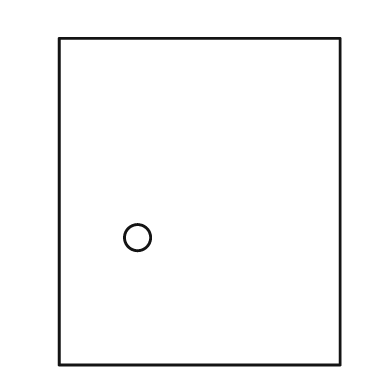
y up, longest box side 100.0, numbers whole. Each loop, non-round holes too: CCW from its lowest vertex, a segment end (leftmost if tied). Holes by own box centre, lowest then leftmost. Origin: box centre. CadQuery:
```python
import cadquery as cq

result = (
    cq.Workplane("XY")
    .moveTo(-43.0, -50.0)
    .lineTo(43.0, -50.0)
    .lineTo(43.0, 50.0)
    .lineTo(-43.0, 50.0)
    .close()
    .moveTo(-19.0, -11.0)
    .circle(4.0)
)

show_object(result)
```